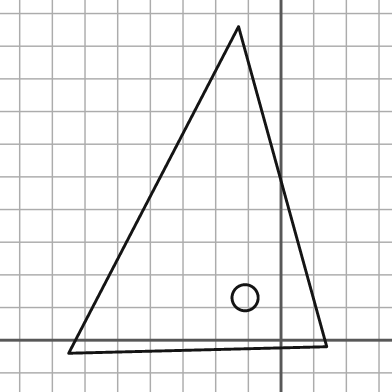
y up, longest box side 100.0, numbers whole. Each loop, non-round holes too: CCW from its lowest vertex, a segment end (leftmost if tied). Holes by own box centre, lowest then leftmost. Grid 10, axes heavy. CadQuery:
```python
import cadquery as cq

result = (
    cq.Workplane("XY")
    .moveTo(-65.0, -4.0)
    .lineTo(14.0, -2.0)
    .lineTo(-13.0, 96.0)
    .close()
    .moveTo(-11.0, 13.0)
    .circle(4.0)
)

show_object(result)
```